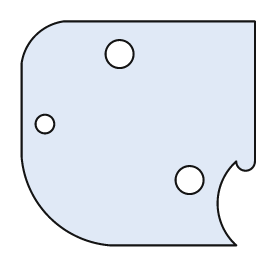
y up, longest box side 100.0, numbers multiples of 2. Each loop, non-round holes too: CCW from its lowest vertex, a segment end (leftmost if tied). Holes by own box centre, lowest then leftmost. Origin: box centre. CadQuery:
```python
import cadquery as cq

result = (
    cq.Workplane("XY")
    .moveTo(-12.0, -48.0)
    .lineTo(42.0, -48.0)
    .threePointArc((34.0, -30.0), (42.0, -12.0))
    .threePointArc((46.0, -16.0), (50.0, -12.0))
    .lineTo(50.0, 48.0)
    .lineTo(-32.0, 48.0)
    .threePointArc((-44.0, 42.0), (-50.0, 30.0))
    .lineTo(-50.0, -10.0)
    .threePointArc((-38.0, -36.0), (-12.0, -48.0))
    .close()
    .moveTo(22.0, -20.0)
    .circle(6.0)
    .moveTo(-40.0, 4.0)
    .circle(4.0)
    .moveTo(-8.0, 34.0)
    .circle(6.0)
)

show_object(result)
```